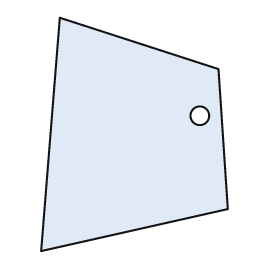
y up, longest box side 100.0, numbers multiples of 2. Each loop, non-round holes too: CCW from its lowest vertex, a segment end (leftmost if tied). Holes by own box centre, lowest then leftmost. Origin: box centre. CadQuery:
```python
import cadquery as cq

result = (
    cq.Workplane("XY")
    .moveTo(-40.0, -50.0)
    .lineTo(40.0, -32.0)
    .lineTo(36.0, 28.0)
    .lineTo(-32.0, 50.0)
    .close()
    .moveTo(28.0, 8.0)
    .circle(4.0)
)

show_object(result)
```